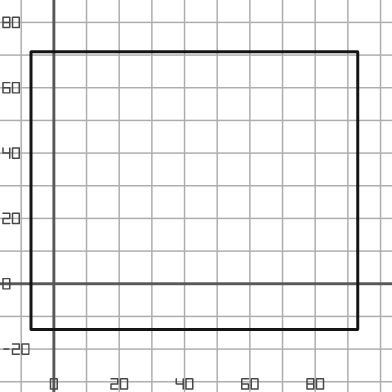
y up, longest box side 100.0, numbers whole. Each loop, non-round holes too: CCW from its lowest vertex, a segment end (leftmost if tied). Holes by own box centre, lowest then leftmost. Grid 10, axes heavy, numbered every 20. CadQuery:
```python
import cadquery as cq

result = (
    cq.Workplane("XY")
    .moveTo(-7.0, -14.0)
    .lineTo(93.0, -14.0)
    .lineTo(93.0, 71.0)
    .lineTo(-7.0, 71.0)
    .close()
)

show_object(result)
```